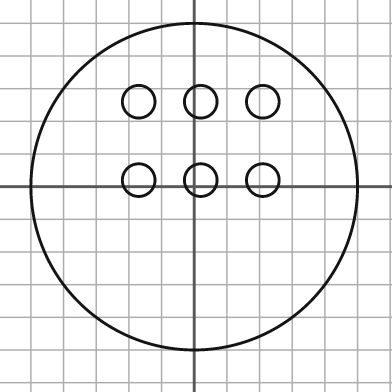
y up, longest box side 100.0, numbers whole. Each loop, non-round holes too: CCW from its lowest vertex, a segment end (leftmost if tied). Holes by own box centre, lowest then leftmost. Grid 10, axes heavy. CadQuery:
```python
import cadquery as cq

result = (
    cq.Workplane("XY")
    .moveTo(0.0, 0.0)
    .circle(50.0)
    .moveTo(-17.0, 2.0)
    .circle(5.0)
    .moveTo(2.0, 2.0)
    .circle(5.0)
    .moveTo(21.0, 2.0)
    .circle(5.0)
    .moveTo(-17.0, 26.0)
    .circle(5.0)
    .moveTo(2.0, 26.0)
    .circle(5.0)
    .moveTo(21.0, 26.0)
    .circle(5.0)
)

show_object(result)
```